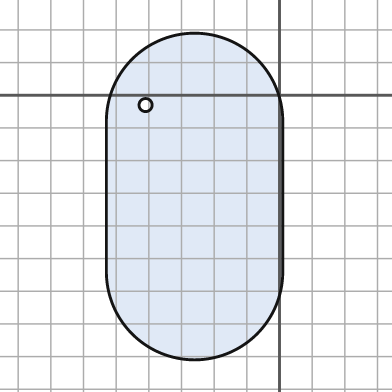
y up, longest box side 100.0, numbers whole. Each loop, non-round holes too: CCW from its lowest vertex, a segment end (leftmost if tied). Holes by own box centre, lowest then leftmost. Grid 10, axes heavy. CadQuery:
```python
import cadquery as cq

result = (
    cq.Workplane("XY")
    .moveTo(-53.0, -54.0)
    .threePointArc((-26.0, -81.0), (1.0, -54.0))
    .lineTo(1.0, -8.0)
    .threePointArc((-26.0, 19.0), (-53.0, -8.0))
    .close()
    .moveTo(-41.0, -3.0)
    .circle(2.0)
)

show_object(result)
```